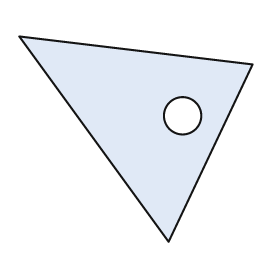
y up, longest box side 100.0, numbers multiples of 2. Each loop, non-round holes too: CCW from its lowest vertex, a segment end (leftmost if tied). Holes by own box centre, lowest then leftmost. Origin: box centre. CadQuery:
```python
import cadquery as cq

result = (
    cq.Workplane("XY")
    .moveTo(14.0, -44.0)
    .lineTo(50.0, 32.0)
    .lineTo(-50.0, 44.0)
    .close()
    .moveTo(20.0, 10.0)
    .circle(8.0)
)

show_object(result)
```